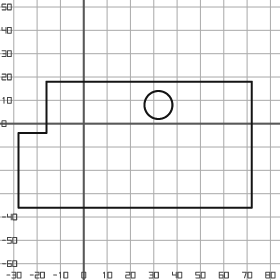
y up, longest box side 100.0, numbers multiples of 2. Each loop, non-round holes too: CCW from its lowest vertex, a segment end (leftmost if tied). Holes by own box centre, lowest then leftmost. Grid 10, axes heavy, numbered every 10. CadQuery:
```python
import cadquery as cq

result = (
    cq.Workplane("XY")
    .moveTo(-28.0, -36.0)
    .lineTo(72.0, -36.0)
    .lineTo(72.0, 18.0)
    .lineTo(-16.0, 18.0)
    .lineTo(-16.0, -4.0)
    .lineTo(-28.0, -4.0)
    .close()
    .moveTo(32.0, 8.0)
    .circle(6.0)
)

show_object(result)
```